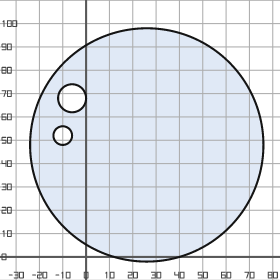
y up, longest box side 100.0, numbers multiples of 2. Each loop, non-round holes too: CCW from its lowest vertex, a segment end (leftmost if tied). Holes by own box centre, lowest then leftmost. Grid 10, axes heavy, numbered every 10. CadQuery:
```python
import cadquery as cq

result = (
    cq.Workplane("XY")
    .moveTo(26.0, 48.0)
    .circle(50.0)
    .moveTo(-10.0, 52.0)
    .circle(4.0)
    .moveTo(-6.0, 68.0)
    .circle(6.0)
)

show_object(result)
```